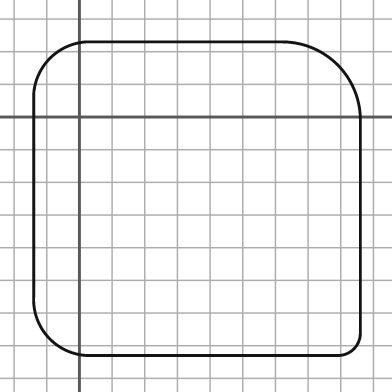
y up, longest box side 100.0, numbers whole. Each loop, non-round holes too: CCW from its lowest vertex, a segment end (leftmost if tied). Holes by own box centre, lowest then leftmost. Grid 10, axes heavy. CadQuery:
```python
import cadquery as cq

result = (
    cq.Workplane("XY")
    .moveTo(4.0, -73.0)
    .lineTo(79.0, -73.0)
    .threePointArc((84.0, -71.0), (86.0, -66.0))
    .lineTo(86.0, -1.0)
    .threePointArc((79.0, 16.0), (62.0, 23.0))
    .lineTo(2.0, 23.0)
    .threePointArc((-9.0, 18.0), (-14.0, 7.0))
    .lineTo(-14.0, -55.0)
    .threePointArc((-9.0, -68.0), (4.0, -73.0))
    .close()
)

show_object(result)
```